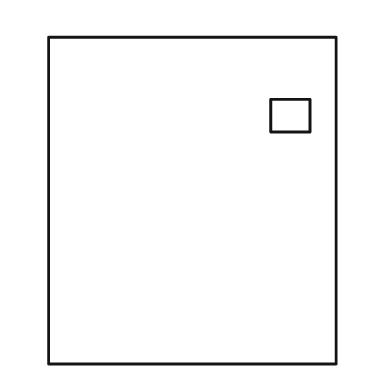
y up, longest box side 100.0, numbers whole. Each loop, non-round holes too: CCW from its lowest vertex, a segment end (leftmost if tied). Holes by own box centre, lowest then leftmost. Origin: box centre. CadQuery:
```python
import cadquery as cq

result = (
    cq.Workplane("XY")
    .moveTo(-44.0, -50.0)
    .lineTo(44.0, -50.0)
    .lineTo(44.0, 50.0)
    .lineTo(-44.0, 50.0)
    .close()
    .moveTo(24.0, 21.0)
    .lineTo(36.0, 21.0)
    .lineTo(36.0, 31.0)
    .lineTo(24.0, 31.0)
    .close()
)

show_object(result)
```